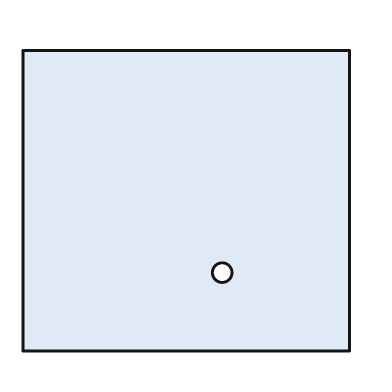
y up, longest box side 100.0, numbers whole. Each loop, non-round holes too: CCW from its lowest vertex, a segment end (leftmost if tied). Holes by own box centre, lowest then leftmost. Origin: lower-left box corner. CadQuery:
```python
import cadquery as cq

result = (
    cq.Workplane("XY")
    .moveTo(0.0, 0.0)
    .lineTo(100.0, 0.0)
    .lineTo(100.0, 92.0)
    .lineTo(0.0, 92.0)
    .close()
    .moveTo(61.0, 24.0)
    .circle(3.0)
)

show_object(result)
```